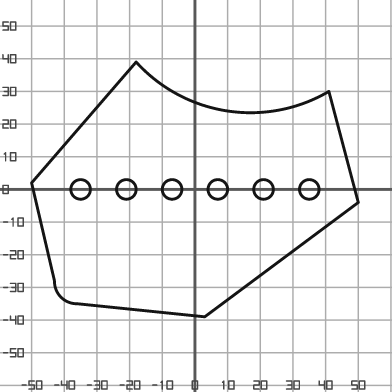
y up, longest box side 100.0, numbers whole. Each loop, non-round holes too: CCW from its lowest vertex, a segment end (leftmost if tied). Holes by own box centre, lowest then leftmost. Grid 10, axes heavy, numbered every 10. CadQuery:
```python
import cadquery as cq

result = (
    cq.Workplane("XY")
    .moveTo(3.0, -39.0)
    .lineTo(50.0, -4.0)
    .lineTo(41.0, 30.0)
    .threePointArc((10.0, 24.0), (-18.0, 39.0))
    .lineTo(-50.0, 2.0)
    .lineTo(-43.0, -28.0)
    .threePointArc((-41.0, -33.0), (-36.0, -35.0))
    .close()
    .moveTo(-35.0, 0.0)
    .circle(3.0)
    .moveTo(-21.0, 0.0)
    .circle(3.0)
    .moveTo(-7.0, 0.0)
    .circle(3.0)
    .moveTo(7.0, 0.0)
    .circle(3.0)
    .moveTo(21.0, 0.0)
    .circle(3.0)
    .moveTo(35.0, 0.0)
    .circle(3.0)
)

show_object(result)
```